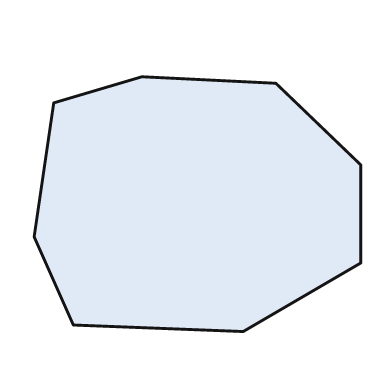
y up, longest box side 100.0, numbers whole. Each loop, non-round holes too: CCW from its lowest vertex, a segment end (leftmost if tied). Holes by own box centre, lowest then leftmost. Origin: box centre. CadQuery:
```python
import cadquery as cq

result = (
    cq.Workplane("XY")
    .moveTo(14.0, -39.0)
    .lineTo(50.0, -18.0)
    .lineTo(50.0, 12.0)
    .lineTo(24.0, 37.0)
    .lineTo(-17.0, 39.0)
    .lineTo(-44.0, 31.0)
    .lineTo(-50.0, -10.0)
    .lineTo(-38.0, -37.0)
    .close()
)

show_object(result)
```